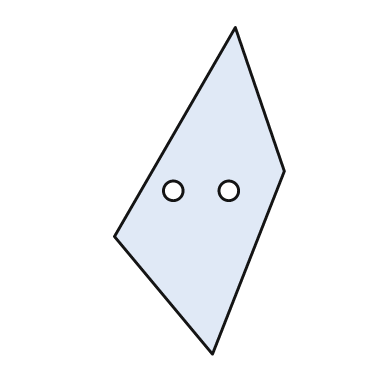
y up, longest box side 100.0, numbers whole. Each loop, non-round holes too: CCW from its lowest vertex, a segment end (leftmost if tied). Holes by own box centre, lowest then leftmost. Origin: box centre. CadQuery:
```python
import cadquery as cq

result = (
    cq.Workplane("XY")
    .moveTo(4.0, -50.0)
    .lineTo(26.0, 6.0)
    .lineTo(11.0, 50.0)
    .lineTo(-26.0, -14.0)
    .close()
    .moveTo(-8.0, 0.0)
    .circle(3.0)
    .moveTo(9.0, 0.0)
    .circle(3.0)
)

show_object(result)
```